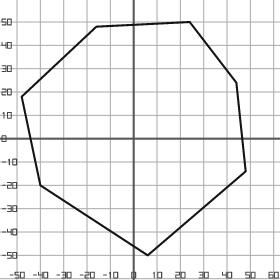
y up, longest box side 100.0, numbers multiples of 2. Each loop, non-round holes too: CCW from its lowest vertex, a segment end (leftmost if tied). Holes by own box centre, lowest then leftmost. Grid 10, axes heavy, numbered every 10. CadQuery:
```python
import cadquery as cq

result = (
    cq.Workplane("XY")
    .moveTo(6.0, -50.0)
    .lineTo(48.0, -14.0)
    .lineTo(44.0, 24.0)
    .lineTo(24.0, 50.0)
    .lineTo(-16.0, 48.0)
    .lineTo(-48.0, 18.0)
    .lineTo(-40.0, -20.0)
    .close()
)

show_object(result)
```